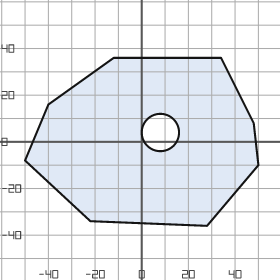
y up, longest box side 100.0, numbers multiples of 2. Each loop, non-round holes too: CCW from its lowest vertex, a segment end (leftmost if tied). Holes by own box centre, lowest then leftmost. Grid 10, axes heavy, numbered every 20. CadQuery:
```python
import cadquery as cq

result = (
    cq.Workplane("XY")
    .moveTo(28.0, -36.0)
    .lineTo(50.0, -10.0)
    .lineTo(48.0, 8.0)
    .lineTo(34.0, 36.0)
    .lineTo(-12.0, 36.0)
    .lineTo(-40.0, 16.0)
    .lineTo(-50.0, -8.0)
    .lineTo(-22.0, -34.0)
    .close()
    .moveTo(8.0, 4.0)
    .circle(8.0)
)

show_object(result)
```